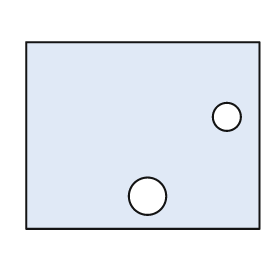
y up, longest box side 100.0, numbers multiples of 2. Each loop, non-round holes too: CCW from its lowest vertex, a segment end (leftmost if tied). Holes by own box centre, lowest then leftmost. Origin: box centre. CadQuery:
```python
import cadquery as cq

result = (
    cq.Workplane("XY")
    .moveTo(-50.0, -40.0)
    .lineTo(50.0, -40.0)
    .lineTo(50.0, 40.0)
    .lineTo(-50.0, 40.0)
    .close()
    .moveTo(2.0, -26.0)
    .circle(8.0)
    .moveTo(36.0, 8.0)
    .circle(6.0)
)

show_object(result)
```